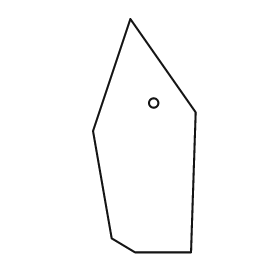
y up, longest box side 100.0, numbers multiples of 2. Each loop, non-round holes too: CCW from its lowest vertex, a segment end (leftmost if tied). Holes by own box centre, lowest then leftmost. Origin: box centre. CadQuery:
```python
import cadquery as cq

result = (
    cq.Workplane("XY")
    .moveTo(-4.0, -50.0)
    .lineTo(20.0, -50.0)
    .lineTo(22.0, 10.0)
    .lineTo(-6.0, 50.0)
    .lineTo(-22.0, 2.0)
    .lineTo(-14.0, -44.0)
    .close()
    .moveTo(4.0, 14.0)
    .circle(2.0)
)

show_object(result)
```